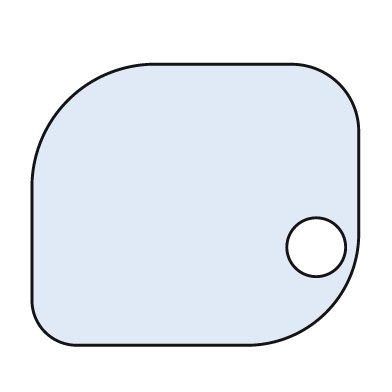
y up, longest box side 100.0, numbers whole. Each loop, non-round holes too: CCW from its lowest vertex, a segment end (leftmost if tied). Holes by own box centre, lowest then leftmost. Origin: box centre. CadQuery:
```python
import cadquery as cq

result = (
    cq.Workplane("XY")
    .moveTo(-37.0, -43.0)
    .lineTo(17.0, -43.0)
    .threePointArc((40.0, -33.0), (50.0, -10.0))
    .lineTo(50.0, 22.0)
    .threePointArc((44.0, 37.0), (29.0, 43.0))
    .lineTo(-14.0, 43.0)
    .threePointArc((-39.0, 32.0), (-50.0, 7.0))
    .lineTo(-50.0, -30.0)
    .threePointArc((-46.0, -39.0), (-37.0, -43.0))
    .close()
    .moveTo(37.0, -13.0)
    .circle(9.0)
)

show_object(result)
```